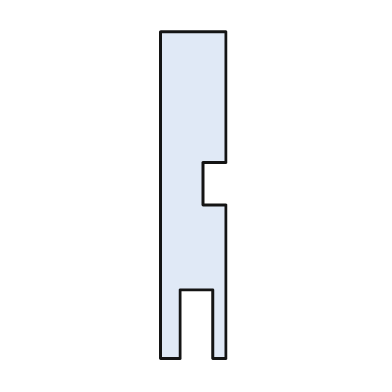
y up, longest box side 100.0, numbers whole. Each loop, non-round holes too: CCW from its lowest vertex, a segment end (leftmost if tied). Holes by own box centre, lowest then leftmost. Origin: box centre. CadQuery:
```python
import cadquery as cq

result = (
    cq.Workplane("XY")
    .moveTo(-10.0, -50.0)
    .lineTo(-4.0, -50.0)
    .lineTo(-4.0, -29.0)
    .lineTo(6.0, -29.0)
    .lineTo(6.0, -50.0)
    .lineTo(10.0, -50.0)
    .lineTo(10.0, -3.0)
    .lineTo(3.0, -3.0)
    .lineTo(3.0, 10.0)
    .lineTo(10.0, 10.0)
    .lineTo(10.0, 50.0)
    .lineTo(-10.0, 50.0)
    .close()
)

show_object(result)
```